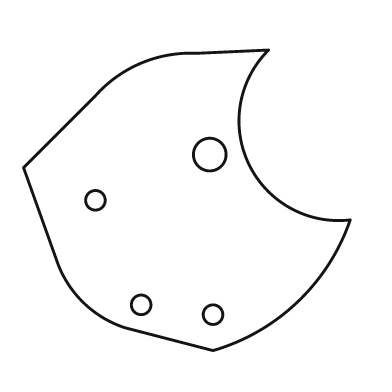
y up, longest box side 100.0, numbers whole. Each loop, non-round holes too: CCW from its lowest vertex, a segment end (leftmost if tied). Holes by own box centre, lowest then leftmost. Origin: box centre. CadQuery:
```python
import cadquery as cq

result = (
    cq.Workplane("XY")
    .moveTo(8.0, -46.0)
    .threePointArc((34.0, -31.0), (50.0, -6.0))
    .threePointArc((19.0, 11.0), (25.0, 46.0))
    .lineTo(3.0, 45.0)
    .threePointArc((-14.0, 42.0), (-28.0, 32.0))
    .lineTo(-50.0, 10.0)
    .lineTo(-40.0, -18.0)
    .threePointArc((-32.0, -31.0), (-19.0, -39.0))
    .close()
    .moveTo(8.0, -35.0)
    .circle(3.0)
    .moveTo(-14.0, -32.0)
    .circle(3.0)
    .moveTo(-28.0, 0.0)
    .circle(3.0)
    .moveTo(7.0, 14.0)
    .circle(5.0)
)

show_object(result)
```